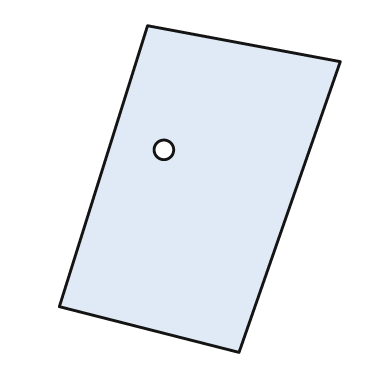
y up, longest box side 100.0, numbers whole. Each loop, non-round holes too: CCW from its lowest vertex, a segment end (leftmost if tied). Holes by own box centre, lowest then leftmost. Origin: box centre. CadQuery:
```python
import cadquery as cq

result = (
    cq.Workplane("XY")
    .moveTo(12.0, -50.0)
    .lineTo(43.0, 39.0)
    .lineTo(-16.0, 50.0)
    .lineTo(-43.0, -36.0)
    .close()
    .moveTo(-11.0, 12.0)
    .circle(3.0)
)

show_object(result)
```